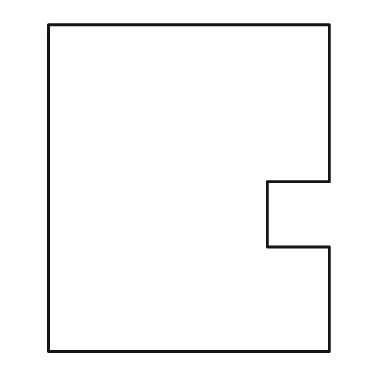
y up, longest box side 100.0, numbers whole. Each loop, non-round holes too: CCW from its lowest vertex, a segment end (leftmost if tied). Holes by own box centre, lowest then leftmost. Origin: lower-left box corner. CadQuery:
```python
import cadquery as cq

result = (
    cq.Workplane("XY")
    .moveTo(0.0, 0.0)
    .lineTo(86.0, 0.0)
    .lineTo(86.0, 32.0)
    .lineTo(67.0, 32.0)
    .lineTo(67.0, 52.0)
    .lineTo(86.0, 52.0)
    .lineTo(86.0, 100.0)
    .lineTo(0.0, 100.0)
    .close()
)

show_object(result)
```